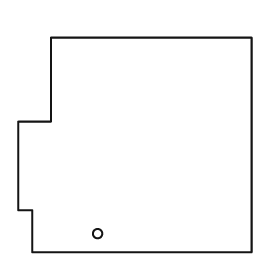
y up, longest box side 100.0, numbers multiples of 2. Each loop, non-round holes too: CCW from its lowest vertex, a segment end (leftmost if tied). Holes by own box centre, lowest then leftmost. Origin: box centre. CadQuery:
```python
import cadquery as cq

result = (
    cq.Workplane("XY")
    .moveTo(-44.0, -46.0)
    .lineTo(50.0, -46.0)
    .lineTo(50.0, 46.0)
    .lineTo(-36.0, 46.0)
    .lineTo(-36.0, 10.0)
    .lineTo(-50.0, 10.0)
    .lineTo(-50.0, -28.0)
    .lineTo(-44.0, -28.0)
    .close()
    .moveTo(-16.0, -38.0)
    .circle(2.0)
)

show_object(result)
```